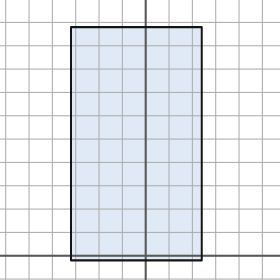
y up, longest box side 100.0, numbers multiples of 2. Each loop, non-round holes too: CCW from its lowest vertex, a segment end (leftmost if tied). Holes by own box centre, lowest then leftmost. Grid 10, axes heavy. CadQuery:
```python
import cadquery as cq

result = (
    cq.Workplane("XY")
    .moveTo(-32.0, -2.0)
    .lineTo(24.0, -2.0)
    .lineTo(24.0, 98.0)
    .lineTo(-32.0, 98.0)
    .close()
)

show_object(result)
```